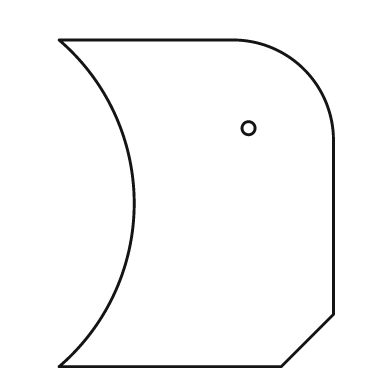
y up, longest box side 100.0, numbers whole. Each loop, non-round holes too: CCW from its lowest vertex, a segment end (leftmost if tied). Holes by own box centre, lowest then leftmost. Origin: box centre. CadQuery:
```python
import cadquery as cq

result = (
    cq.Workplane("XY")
    .moveTo(-42.0, -50.0)
    .lineTo(26.0, -50.0)
    .lineTo(42.0, -34.0)
    .lineTo(42.0, 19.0)
    .threePointArc((33.0, 41.0), (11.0, 50.0))
    .lineTo(-42.0, 50.0)
    .threePointArc((-19.0, 0.0), (-42.0, -50.0))
    .close()
    .moveTo(16.0, 23.0)
    .circle(2.0)
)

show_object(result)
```